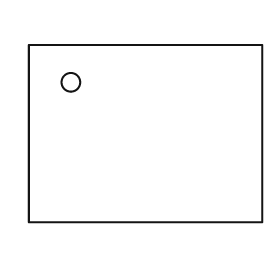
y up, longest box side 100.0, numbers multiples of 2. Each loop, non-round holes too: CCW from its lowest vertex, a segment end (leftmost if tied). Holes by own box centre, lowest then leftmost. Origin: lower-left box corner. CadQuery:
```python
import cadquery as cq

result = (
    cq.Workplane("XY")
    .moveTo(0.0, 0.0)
    .lineTo(100.0, 0.0)
    .lineTo(100.0, 76.0)
    .lineTo(0.0, 76.0)
    .close()
    .moveTo(18.0, 60.0)
    .circle(4.0)
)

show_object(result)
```